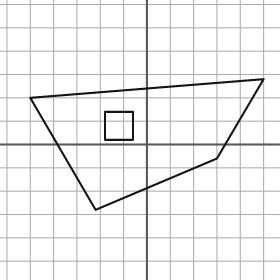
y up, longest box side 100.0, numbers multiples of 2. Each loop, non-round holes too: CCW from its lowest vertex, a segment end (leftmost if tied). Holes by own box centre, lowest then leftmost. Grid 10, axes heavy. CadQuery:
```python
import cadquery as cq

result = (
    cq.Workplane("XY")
    .moveTo(-22.0, -28.0)
    .lineTo(30.0, -6.0)
    .lineTo(50.0, 28.0)
    .lineTo(-50.0, 20.0)
    .close()
    .moveTo(-18.0, 2.0)
    .lineTo(-6.0, 2.0)
    .lineTo(-6.0, 14.0)
    .lineTo(-18.0, 14.0)
    .close()
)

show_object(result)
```